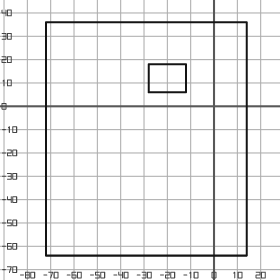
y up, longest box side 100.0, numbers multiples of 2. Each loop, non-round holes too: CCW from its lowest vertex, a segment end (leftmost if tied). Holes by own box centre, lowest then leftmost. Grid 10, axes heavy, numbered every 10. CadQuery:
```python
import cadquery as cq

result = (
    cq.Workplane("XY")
    .moveTo(-72.0, -64.0)
    .lineTo(14.0, -64.0)
    .lineTo(14.0, 36.0)
    .lineTo(-72.0, 36.0)
    .close()
    .moveTo(-28.0, 6.0)
    .lineTo(-12.0, 6.0)
    .lineTo(-12.0, 18.0)
    .lineTo(-28.0, 18.0)
    .close()
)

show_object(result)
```